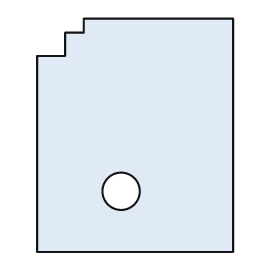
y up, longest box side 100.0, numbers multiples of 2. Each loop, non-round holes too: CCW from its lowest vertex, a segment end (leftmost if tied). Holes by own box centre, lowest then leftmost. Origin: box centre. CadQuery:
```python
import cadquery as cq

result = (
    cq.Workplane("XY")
    .moveTo(-42.0, -50.0)
    .lineTo(42.0, -50.0)
    .lineTo(42.0, 50.0)
    .lineTo(-22.0, 50.0)
    .lineTo(-22.0, 44.0)
    .lineTo(-30.0, 44.0)
    .lineTo(-30.0, 34.0)
    .lineTo(-42.0, 34.0)
    .close()
    .moveTo(-6.0, -24.0)
    .circle(8.0)
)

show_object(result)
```